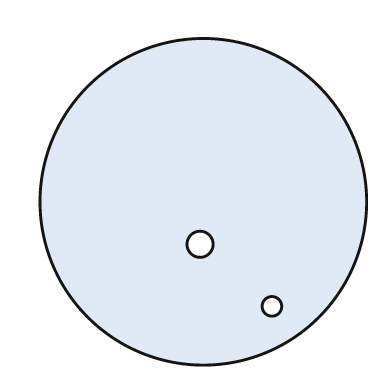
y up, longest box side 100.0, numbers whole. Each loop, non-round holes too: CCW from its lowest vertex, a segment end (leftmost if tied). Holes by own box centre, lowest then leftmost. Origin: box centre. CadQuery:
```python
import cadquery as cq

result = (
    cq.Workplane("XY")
    .moveTo(0.0, 0.0)
    .circle(50.0)
    .moveTo(21.0, -32.0)
    .circle(3.0)
    .moveTo(-1.0, -13.0)
    .circle(4.0)
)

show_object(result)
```